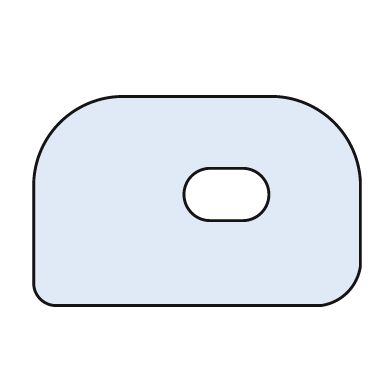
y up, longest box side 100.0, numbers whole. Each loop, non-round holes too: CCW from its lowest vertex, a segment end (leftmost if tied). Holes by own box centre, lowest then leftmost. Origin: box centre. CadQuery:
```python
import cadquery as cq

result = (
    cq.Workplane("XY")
    .moveTo(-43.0, -32.0)
    .lineTo(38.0, -32.0)
    .threePointArc((46.0, -28.0), (50.0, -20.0))
    .lineTo(50.0, 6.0)
    .threePointArc((42.0, 24.0), (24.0, 32.0))
    .lineTo(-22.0, 32.0)
    .threePointArc((-42.0, 24.0), (-50.0, 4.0))
    .lineTo(-50.0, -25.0)
    .threePointArc((-48.0, -30.0), (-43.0, -32.0))
    .close()
    .moveTo(4.0, -6.0)
    .lineTo(14.0, -6.0)
    .threePointArc((22.0, 2.0), (14.0, 10.0))
    .lineTo(4.0, 10.0)
    .threePointArc((-4.0, 2.0), (4.0, -6.0))
    .close()
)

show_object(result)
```